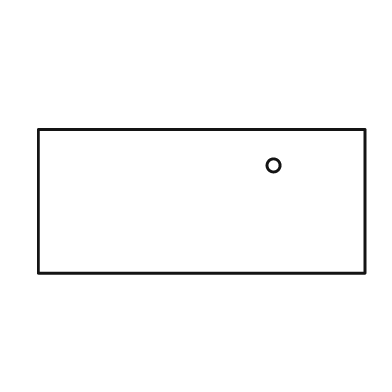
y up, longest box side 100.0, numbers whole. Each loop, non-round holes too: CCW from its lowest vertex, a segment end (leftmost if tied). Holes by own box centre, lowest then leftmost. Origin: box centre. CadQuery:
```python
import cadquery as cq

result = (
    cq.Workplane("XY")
    .moveTo(-50.0, -22.0)
    .lineTo(50.0, -22.0)
    .lineTo(50.0, 22.0)
    .lineTo(-50.0, 22.0)
    .close()
    .moveTo(22.0, 11.0)
    .circle(2.0)
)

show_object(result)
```